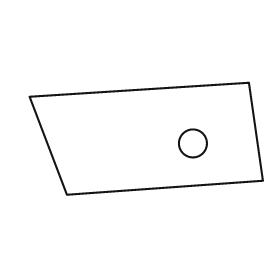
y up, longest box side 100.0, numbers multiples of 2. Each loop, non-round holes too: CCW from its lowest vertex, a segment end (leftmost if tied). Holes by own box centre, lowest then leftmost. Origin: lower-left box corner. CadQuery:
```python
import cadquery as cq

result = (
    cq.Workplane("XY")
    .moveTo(16.0, 0.0)
    .lineTo(100.0, 6.0)
    .lineTo(94.0, 48.0)
    .lineTo(0.0, 42.0)
    .close()
    .moveTo(70.0, 22.0)
    .circle(6.0)
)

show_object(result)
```